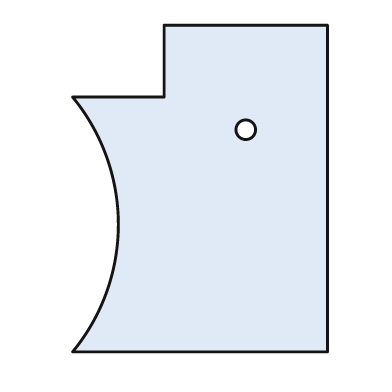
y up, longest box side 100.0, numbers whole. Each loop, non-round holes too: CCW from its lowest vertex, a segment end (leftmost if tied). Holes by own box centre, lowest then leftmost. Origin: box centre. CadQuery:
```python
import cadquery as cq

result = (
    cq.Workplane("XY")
    .moveTo(-39.0, -50.0)
    .lineTo(39.0, -50.0)
    .lineTo(39.0, 50.0)
    .lineTo(-11.0, 50.0)
    .lineTo(-11.0, 28.0)
    .lineTo(-39.0, 28.0)
    .threePointArc((-25.0, -11.0), (-39.0, -50.0))
    .close()
    .moveTo(14.0, 18.0)
    .circle(3.0)
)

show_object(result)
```